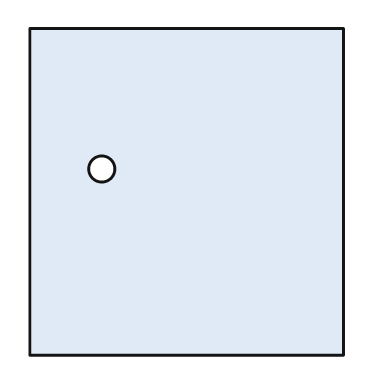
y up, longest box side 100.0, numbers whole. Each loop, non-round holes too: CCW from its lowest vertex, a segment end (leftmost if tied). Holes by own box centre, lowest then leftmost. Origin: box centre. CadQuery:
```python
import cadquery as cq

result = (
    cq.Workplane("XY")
    .moveTo(-48.0, -50.0)
    .lineTo(48.0, -50.0)
    .lineTo(48.0, 50.0)
    .lineTo(-48.0, 50.0)
    .close()
    .moveTo(-26.0, 7.0)
    .circle(4.0)
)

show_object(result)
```